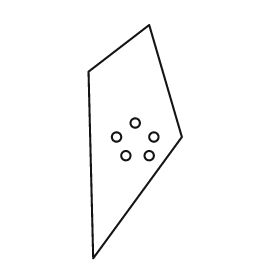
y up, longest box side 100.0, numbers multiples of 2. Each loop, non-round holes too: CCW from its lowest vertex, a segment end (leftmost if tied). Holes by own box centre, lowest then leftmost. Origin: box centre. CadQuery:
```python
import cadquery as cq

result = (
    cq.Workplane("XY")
    .moveTo(-18.0, -50.0)
    .lineTo(20.0, 2.0)
    .lineTo(6.0, 50.0)
    .lineTo(-20.0, 30.0)
    .close()
    .moveTo(-4.0, -6.0)
    .circle(2.0)
    .moveTo(6.0, -6.0)
    .circle(2.0)
    .moveTo(-8.0, 2.0)
    .circle(2.0)
    .moveTo(8.0, 2.0)
    .circle(2.0)
    .moveTo(0.0, 8.0)
    .circle(2.0)
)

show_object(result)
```